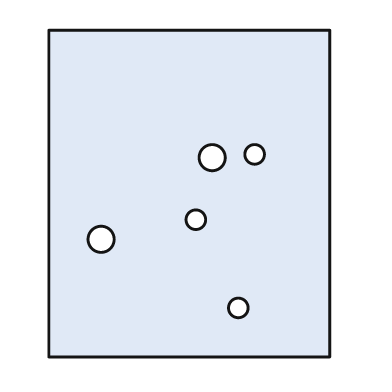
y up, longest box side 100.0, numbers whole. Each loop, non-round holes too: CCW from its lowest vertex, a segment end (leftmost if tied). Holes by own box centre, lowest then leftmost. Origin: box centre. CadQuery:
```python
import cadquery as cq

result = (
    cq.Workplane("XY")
    .moveTo(-43.0, -50.0)
    .lineTo(43.0, -50.0)
    .lineTo(43.0, 50.0)
    .lineTo(-43.0, 50.0)
    .close()
    .moveTo(15.0, -35.0)
    .circle(3.0)
    .moveTo(-27.0, -14.0)
    .circle(4.0)
    .moveTo(2.0, -8.0)
    .circle(3.0)
    .moveTo(7.0, 11.0)
    .circle(4.0)
    .moveTo(20.0, 12.0)
    .circle(3.0)
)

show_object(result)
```